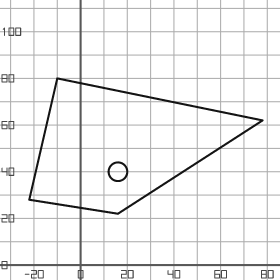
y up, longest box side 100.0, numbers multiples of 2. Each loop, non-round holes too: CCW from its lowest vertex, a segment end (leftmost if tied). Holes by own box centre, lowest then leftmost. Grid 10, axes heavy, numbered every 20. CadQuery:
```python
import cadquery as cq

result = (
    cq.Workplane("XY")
    .moveTo(16.0, 22.0)
    .lineTo(78.0, 62.0)
    .lineTo(-10.0, 80.0)
    .lineTo(-22.0, 28.0)
    .close()
    .moveTo(16.0, 40.0)
    .circle(4.0)
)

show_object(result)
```